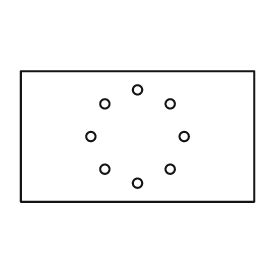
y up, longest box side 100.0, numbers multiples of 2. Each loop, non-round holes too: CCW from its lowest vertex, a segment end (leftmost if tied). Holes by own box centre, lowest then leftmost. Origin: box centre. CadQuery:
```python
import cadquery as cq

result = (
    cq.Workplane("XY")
    .moveTo(-50.0, -28.0)
    .lineTo(50.0, -28.0)
    .lineTo(50.0, 28.0)
    .lineTo(-50.0, 28.0)
    .close()
    .moveTo(0.0, -20.0)
    .circle(2.0)
    .moveTo(-14.0, -14.0)
    .circle(2.0)
    .moveTo(14.0, -14.0)
    .circle(2.0)
    .moveTo(-20.0, 0.0)
    .circle(2.0)
    .moveTo(20.0, 0.0)
    .circle(2.0)
    .moveTo(-14.0, 14.0)
    .circle(2.0)
    .moveTo(14.0, 14.0)
    .circle(2.0)
    .moveTo(0.0, 20.0)
    .circle(2.0)
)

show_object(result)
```